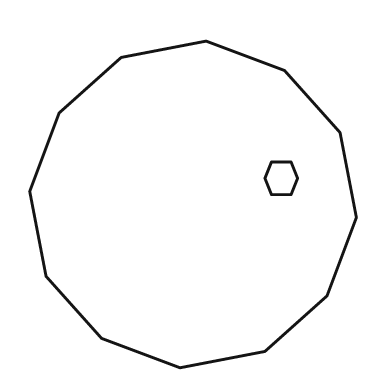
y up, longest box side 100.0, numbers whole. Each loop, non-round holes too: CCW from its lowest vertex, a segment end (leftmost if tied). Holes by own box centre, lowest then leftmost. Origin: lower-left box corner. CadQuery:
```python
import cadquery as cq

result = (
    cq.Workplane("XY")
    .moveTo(46.0, 0.0)
    .lineTo(72.0, 5.0)
    .lineTo(91.0, 22.0)
    .lineTo(100.0, 46.0)
    .lineTo(95.0, 72.0)
    .lineTo(78.0, 91.0)
    .lineTo(54.0, 100.0)
    .lineTo(28.0, 95.0)
    .lineTo(9.0, 78.0)
    .lineTo(0.0, 54.0)
    .lineTo(5.0, 28.0)
    .lineTo(22.0, 9.0)
    .close()
    .moveTo(74.0, 53.0)
    .lineTo(80.0, 53.0)
    .lineTo(82.0, 58.0)
    .lineTo(80.0, 63.0)
    .lineTo(74.0, 63.0)
    .lineTo(72.0, 58.0)
    .close()
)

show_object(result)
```